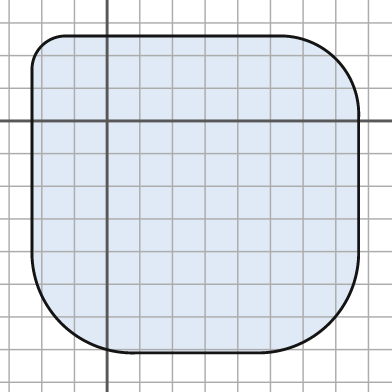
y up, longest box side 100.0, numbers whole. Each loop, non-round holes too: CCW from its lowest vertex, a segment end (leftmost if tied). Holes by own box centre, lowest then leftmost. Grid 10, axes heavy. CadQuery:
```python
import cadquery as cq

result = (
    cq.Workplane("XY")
    .moveTo(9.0, -71.0)
    .lineTo(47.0, -71.0)
    .threePointArc((68.0, -62.0), (77.0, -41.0))
    .lineTo(77.0, 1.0)
    .threePointArc((70.0, 19.0), (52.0, 26.0))
    .lineTo(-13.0, 26.0)
    .threePointArc((-20.0, 23.0), (-23.0, 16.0))
    .lineTo(-23.0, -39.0)
    .threePointArc((-14.0, -62.0), (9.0, -71.0))
    .close()
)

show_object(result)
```